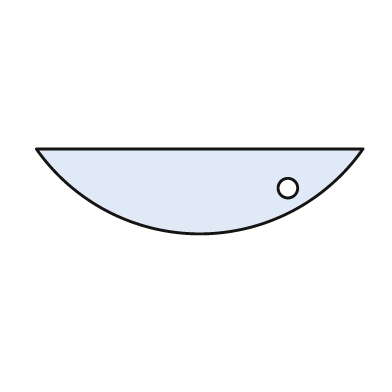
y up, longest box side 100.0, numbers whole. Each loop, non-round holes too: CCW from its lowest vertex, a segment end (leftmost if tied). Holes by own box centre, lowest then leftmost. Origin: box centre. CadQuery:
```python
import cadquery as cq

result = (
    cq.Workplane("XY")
    .moveTo(-50.0, 13.0)
    .threePointArc((0.0, -13.0), (50.0, 13.0))
    .close()
    .moveTo(27.0, 1.0)
    .circle(3.0)
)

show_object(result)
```